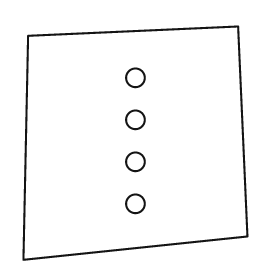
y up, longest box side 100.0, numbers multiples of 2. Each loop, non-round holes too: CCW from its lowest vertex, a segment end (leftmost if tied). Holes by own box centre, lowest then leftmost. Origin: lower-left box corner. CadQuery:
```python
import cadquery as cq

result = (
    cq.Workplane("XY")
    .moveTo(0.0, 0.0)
    .lineTo(96.0, 10.0)
    .lineTo(92.0, 100.0)
    .lineTo(2.0, 96.0)
    .close()
    .moveTo(48.0, 24.0)
    .circle(4.0)
    .moveTo(48.0, 42.0)
    .circle(4.0)
    .moveTo(48.0, 60.0)
    .circle(4.0)
    .moveTo(48.0, 78.0)
    .circle(4.0)
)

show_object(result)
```